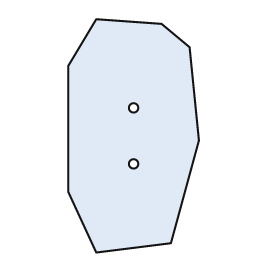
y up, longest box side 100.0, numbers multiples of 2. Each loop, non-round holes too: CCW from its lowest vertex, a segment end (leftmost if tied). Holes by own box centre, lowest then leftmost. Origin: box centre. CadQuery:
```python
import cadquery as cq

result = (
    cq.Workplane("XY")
    .moveTo(-16.0, -50.0)
    .lineTo(16.0, -46.0)
    .lineTo(28.0, -2.0)
    .lineTo(24.0, 38.0)
    .lineTo(12.0, 48.0)
    .lineTo(-16.0, 50.0)
    .lineTo(-28.0, 30.0)
    .lineTo(-28.0, -24.0)
    .close()
    .moveTo(0.0, -12.0)
    .circle(2.0)
    .moveTo(0.0, 12.0)
    .circle(2.0)
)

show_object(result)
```